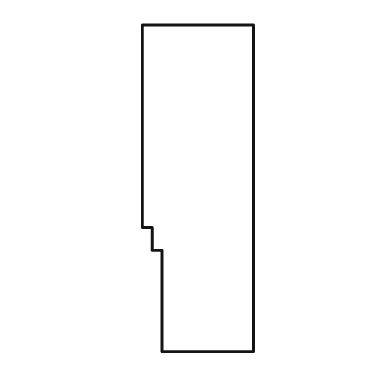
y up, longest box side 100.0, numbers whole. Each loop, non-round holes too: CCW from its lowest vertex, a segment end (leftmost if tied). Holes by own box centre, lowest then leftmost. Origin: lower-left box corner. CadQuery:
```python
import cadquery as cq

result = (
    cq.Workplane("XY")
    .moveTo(6.0, 0.0)
    .lineTo(34.0, 0.0)
    .lineTo(34.0, 100.0)
    .lineTo(0.0, 100.0)
    .lineTo(0.0, 38.0)
    .lineTo(3.0, 38.0)
    .lineTo(3.0, 31.0)
    .lineTo(6.0, 31.0)
    .close()
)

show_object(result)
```